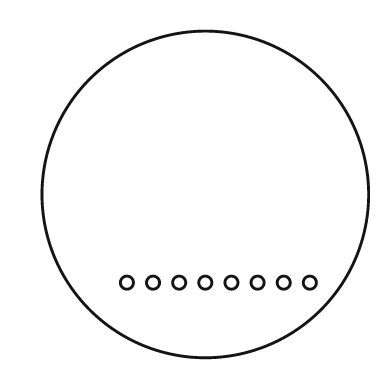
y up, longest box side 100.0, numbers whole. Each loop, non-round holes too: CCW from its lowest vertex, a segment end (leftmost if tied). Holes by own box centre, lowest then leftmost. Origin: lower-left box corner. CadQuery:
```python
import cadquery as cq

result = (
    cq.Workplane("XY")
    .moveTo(50.0, 50.0)
    .circle(50.0)
    .moveTo(26.0, 23.0)
    .circle(2.0)
    .moveTo(34.0, 23.0)
    .circle(2.0)
    .moveTo(42.0, 23.0)
    .circle(2.0)
    .moveTo(50.0, 23.0)
    .circle(2.0)
    .moveTo(58.0, 23.0)
    .circle(2.0)
    .moveTo(66.0, 23.0)
    .circle(2.0)
    .moveTo(74.0, 23.0)
    .circle(2.0)
    .moveTo(82.0, 23.0)
    .circle(2.0)
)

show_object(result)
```